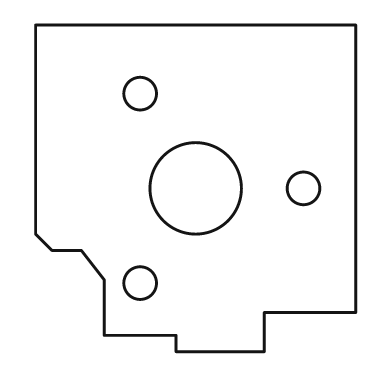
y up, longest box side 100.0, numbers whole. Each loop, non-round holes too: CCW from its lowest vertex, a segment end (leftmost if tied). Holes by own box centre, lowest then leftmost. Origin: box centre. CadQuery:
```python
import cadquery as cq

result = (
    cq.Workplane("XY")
    .moveTo(-6.0, -50.0)
    .lineTo(21.0, -50.0)
    .lineTo(21.0, -38.0)
    .lineTo(49.0, -38.0)
    .lineTo(49.0, 50.0)
    .lineTo(-49.0, 50.0)
    .lineTo(-49.0, -14.0)
    .lineTo(-44.0, -19.0)
    .lineTo(-35.0, -19.0)
    .lineTo(-28.0, -28.0)
    .lineTo(-28.0, -45.0)
    .lineTo(-6.0, -45.0)
    .close()
    .moveTo(-17.0, -29.0)
    .circle(5.0)
    .moveTo(0.0, 0.0)
    .circle(14.0)
    .moveTo(33.0, 0.0)
    .circle(5.0)
    .moveTo(-17.0, 29.0)
    .circle(5.0)
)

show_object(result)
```